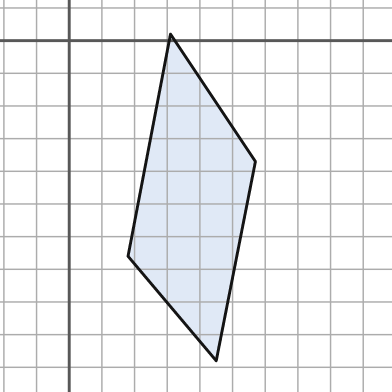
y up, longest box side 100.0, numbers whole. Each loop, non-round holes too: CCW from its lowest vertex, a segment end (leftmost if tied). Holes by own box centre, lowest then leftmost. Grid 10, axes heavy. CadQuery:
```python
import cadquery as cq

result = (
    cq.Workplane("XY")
    .moveTo(45.0, -98.0)
    .lineTo(57.0, -37.0)
    .lineTo(31.0, 2.0)
    .lineTo(18.0, -66.0)
    .close()
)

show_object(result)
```